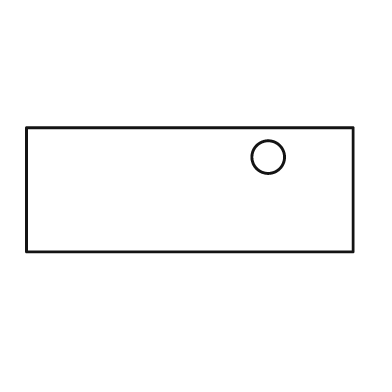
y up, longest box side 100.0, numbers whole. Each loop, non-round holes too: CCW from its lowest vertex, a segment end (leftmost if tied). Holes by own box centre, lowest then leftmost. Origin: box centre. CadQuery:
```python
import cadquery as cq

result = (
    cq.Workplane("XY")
    .moveTo(-50.0, -19.0)
    .lineTo(50.0, -19.0)
    .lineTo(50.0, 19.0)
    .lineTo(-50.0, 19.0)
    .close()
    .moveTo(24.0, 10.0)
    .circle(5.0)
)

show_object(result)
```